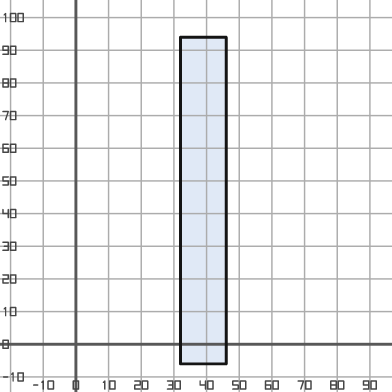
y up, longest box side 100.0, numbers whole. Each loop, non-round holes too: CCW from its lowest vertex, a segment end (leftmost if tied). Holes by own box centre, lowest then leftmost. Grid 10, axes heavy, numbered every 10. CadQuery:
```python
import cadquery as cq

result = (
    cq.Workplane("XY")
    .moveTo(32.0, -6.0)
    .lineTo(46.0, -6.0)
    .lineTo(46.0, 94.0)
    .lineTo(32.0, 94.0)
    .close()
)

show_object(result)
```